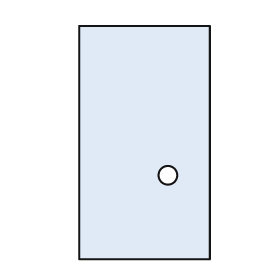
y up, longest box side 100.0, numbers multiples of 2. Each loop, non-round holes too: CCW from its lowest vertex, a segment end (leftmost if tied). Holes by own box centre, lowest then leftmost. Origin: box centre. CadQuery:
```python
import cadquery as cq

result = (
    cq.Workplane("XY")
    .moveTo(-28.0, -50.0)
    .lineTo(28.0, -50.0)
    .lineTo(28.0, 50.0)
    .lineTo(-28.0, 50.0)
    .close()
    .moveTo(10.0, -14.0)
    .circle(4.0)
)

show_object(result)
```